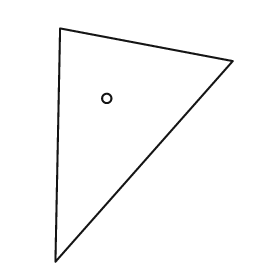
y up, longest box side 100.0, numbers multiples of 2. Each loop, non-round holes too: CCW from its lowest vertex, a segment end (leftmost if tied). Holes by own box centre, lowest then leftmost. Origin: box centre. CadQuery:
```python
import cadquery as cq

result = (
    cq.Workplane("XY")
    .moveTo(-38.0, -50.0)
    .lineTo(38.0, 36.0)
    .lineTo(-36.0, 50.0)
    .close()
    .moveTo(-16.0, 20.0)
    .circle(2.0)
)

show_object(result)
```